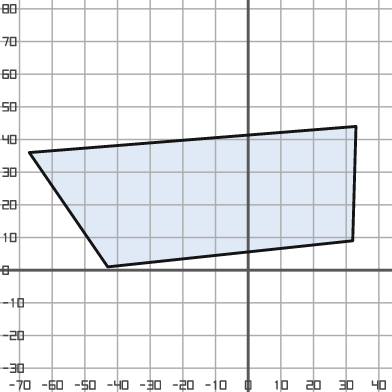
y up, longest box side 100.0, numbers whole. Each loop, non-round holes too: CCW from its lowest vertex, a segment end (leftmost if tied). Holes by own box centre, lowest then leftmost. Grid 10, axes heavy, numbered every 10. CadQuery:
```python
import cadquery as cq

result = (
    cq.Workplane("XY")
    .moveTo(-43.0, 1.0)
    .lineTo(32.0, 9.0)
    .lineTo(33.0, 44.0)
    .lineTo(-67.0, 36.0)
    .close()
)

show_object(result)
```